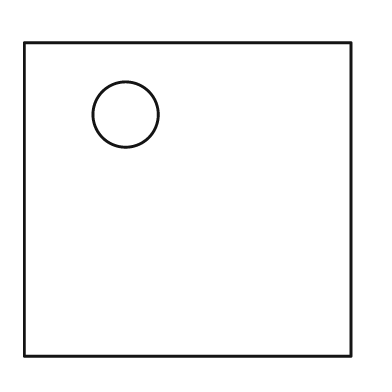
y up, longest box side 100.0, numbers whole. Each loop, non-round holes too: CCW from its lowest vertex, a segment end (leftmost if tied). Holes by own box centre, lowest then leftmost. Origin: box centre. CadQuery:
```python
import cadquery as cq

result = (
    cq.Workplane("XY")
    .moveTo(-50.0, -48.0)
    .lineTo(50.0, -48.0)
    .lineTo(50.0, 48.0)
    .lineTo(-50.0, 48.0)
    .close()
    .moveTo(-19.0, 26.0)
    .circle(10.0)
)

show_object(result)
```